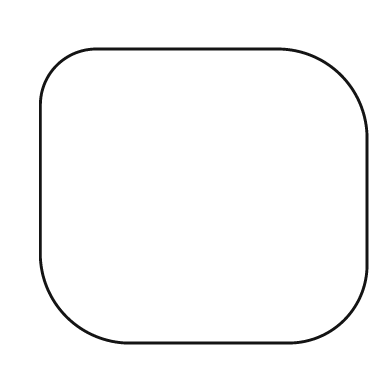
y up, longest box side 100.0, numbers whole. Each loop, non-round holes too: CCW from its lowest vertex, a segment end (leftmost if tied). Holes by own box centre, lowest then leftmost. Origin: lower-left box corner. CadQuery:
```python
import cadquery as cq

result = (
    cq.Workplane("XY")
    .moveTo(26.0, 0.0)
    .lineTo(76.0, 0.0)
    .threePointArc((93.0, 7.0), (100.0, 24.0))
    .lineTo(100.0, 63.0)
    .threePointArc((92.0, 82.0), (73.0, 90.0))
    .lineTo(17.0, 90.0)
    .threePointArc((5.0, 85.0), (0.0, 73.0))
    .lineTo(0.0, 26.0)
    .threePointArc((8.0, 8.0), (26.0, 0.0))
    .close()
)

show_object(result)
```